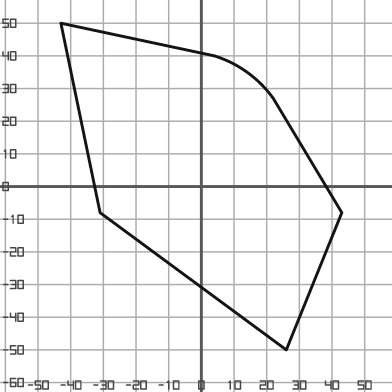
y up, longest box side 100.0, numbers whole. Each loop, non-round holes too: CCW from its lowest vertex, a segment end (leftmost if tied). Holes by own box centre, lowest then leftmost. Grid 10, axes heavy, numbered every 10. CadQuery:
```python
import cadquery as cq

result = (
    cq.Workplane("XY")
    .moveTo(26.0, -50.0)
    .lineTo(43.0, -8.0)
    .lineTo(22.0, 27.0)
    .threePointArc((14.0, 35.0), (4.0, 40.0))
    .lineTo(-43.0, 50.0)
    .lineTo(-31.0, -8.0)
    .close()
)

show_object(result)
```